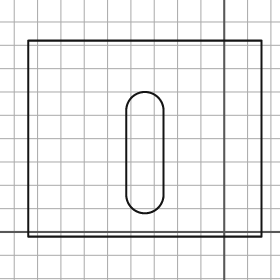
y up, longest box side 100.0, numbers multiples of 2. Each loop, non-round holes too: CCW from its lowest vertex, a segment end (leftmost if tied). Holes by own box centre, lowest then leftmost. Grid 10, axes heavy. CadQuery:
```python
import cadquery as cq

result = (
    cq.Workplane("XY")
    .moveTo(-84.0, -2.0)
    .lineTo(16.0, -2.0)
    .lineTo(16.0, 82.0)
    .lineTo(-84.0, 82.0)
    .close()
    .moveTo(-42.0, 16.0)
    .threePointArc((-34.0, 8.0), (-26.0, 16.0))
    .lineTo(-26.0, 52.0)
    .threePointArc((-34.0, 60.0), (-42.0, 52.0))
    .close()
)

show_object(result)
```